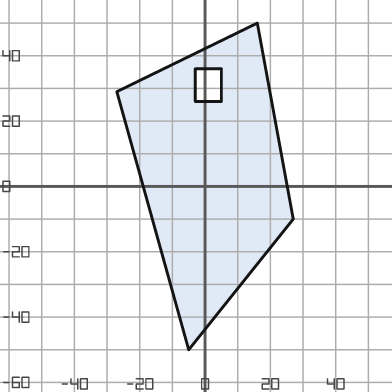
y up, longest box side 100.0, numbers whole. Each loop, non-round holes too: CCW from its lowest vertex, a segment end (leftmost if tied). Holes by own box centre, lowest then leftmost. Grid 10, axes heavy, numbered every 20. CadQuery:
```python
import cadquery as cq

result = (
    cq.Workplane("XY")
    .moveTo(-5.0, -50.0)
    .lineTo(27.0, -10.0)
    .lineTo(16.0, 50.0)
    .lineTo(-27.0, 29.0)
    .close()
    .moveTo(-3.0, 26.0)
    .lineTo(5.0, 26.0)
    .lineTo(5.0, 36.0)
    .lineTo(-3.0, 36.0)
    .close()
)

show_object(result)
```